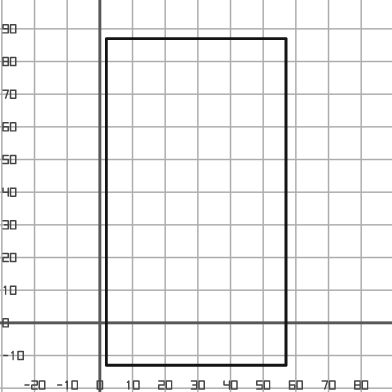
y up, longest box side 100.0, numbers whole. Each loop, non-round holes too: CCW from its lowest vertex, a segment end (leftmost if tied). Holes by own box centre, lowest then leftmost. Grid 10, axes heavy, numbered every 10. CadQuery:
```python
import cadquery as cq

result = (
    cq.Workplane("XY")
    .moveTo(2.0, -13.0)
    .lineTo(57.0, -13.0)
    .lineTo(57.0, 87.0)
    .lineTo(2.0, 87.0)
    .close()
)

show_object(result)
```